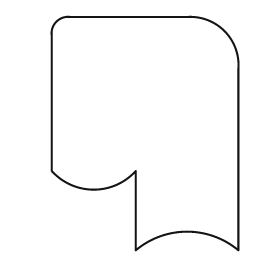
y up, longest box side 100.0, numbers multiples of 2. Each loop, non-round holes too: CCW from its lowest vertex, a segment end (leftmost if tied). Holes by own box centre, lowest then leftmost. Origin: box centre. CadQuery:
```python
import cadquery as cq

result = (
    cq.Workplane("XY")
    .moveTo(-4.0, -50.0)
    .threePointArc((18.0, -42.0), (40.0, -50.0))
    .lineTo(40.0, 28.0)
    .threePointArc((34.0, 44.0), (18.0, 50.0))
    .lineTo(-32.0, 50.0)
    .threePointArc((-38.0, 48.0), (-40.0, 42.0))
    .lineTo(-40.0, -16.0)
    .threePointArc((-22.0, -24.0), (-4.0, -16.0))
    .close()
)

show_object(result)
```